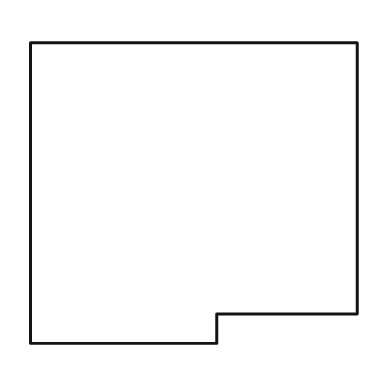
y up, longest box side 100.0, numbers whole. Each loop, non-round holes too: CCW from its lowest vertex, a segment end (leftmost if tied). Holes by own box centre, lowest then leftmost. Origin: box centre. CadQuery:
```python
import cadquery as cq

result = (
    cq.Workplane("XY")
    .moveTo(-50.0, -46.0)
    .lineTo(7.0, -46.0)
    .lineTo(7.0, -37.0)
    .lineTo(50.0, -37.0)
    .lineTo(50.0, 46.0)
    .lineTo(-50.0, 46.0)
    .close()
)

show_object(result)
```